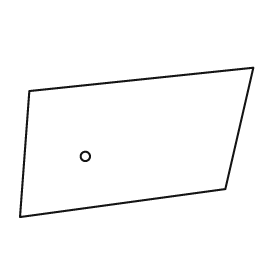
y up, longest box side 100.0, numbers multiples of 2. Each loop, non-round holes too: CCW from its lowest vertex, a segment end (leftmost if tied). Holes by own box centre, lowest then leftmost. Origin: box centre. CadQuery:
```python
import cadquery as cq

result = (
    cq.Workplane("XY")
    .moveTo(-50.0, -32.0)
    .lineTo(38.0, -20.0)
    .lineTo(50.0, 32.0)
    .lineTo(-46.0, 22.0)
    .close()
    .moveTo(-22.0, -6.0)
    .circle(2.0)
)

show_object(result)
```